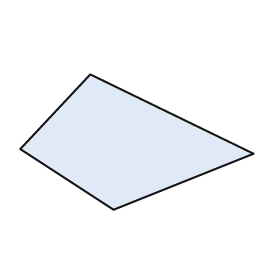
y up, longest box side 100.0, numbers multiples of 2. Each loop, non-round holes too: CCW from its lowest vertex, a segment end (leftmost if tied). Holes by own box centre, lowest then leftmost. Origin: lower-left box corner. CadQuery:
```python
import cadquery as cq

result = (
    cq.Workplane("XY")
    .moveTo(40.0, 0.0)
    .lineTo(100.0, 24.0)
    .lineTo(30.0, 58.0)
    .lineTo(0.0, 26.0)
    .close()
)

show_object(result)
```